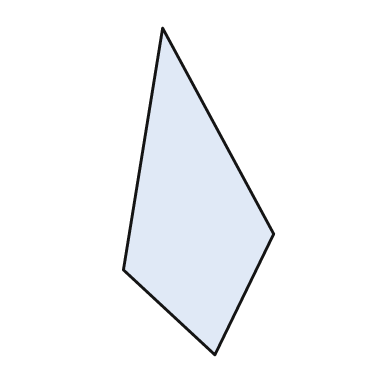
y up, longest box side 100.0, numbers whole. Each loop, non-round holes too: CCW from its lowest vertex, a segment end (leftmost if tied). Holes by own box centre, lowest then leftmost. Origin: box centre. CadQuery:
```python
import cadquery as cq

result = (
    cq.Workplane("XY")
    .moveTo(5.0, -50.0)
    .lineTo(23.0, -13.0)
    .lineTo(-11.0, 50.0)
    .lineTo(-23.0, -24.0)
    .close()
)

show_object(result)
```